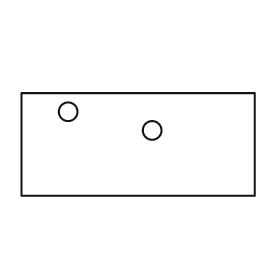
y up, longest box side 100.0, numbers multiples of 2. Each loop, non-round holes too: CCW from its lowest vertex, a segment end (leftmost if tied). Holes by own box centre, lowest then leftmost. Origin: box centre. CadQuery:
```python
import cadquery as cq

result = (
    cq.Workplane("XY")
    .moveTo(-50.0, -22.0)
    .lineTo(50.0, -22.0)
    .lineTo(50.0, 22.0)
    .lineTo(-50.0, 22.0)
    .close()
    .moveTo(6.0, 6.0)
    .circle(4.0)
    .moveTo(-30.0, 14.0)
    .circle(4.0)
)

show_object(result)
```